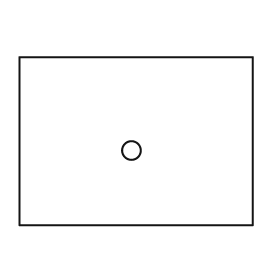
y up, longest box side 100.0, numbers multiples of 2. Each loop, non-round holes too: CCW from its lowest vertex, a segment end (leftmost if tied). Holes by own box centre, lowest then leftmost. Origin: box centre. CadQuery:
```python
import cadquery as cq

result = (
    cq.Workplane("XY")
    .moveTo(-50.0, -36.0)
    .lineTo(50.0, -36.0)
    .lineTo(50.0, 36.0)
    .lineTo(-50.0, 36.0)
    .close()
    .moveTo(-2.0, -4.0)
    .circle(4.0)
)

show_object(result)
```